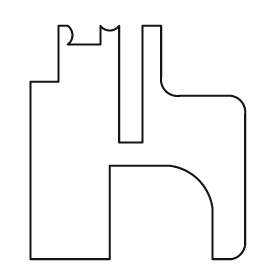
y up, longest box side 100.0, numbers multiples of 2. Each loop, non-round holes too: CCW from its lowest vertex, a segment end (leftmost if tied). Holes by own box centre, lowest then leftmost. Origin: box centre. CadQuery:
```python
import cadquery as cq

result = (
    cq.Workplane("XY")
    .moveTo(-46.0, -50.0)
    .lineTo(-12.0, -50.0)
    .lineTo(-12.0, -10.0)
    .lineTo(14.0, -10.0)
    .threePointArc((26.0, -16.0), (32.0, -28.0))
    .lineTo(32.0, -50.0)
    .lineTo(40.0, -50.0)
    .threePointArc((44.0, -48.0), (46.0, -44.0))
    .lineTo(46.0, 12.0)
    .threePointArc((44.0, 18.0), (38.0, 20.0))
    .lineTo(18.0, 20.0)
    .threePointArc((12.0, 22.0), (10.0, 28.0))
    .lineTo(10.0, 50.0)
    .lineTo(2.0, 50.0)
    .lineTo(2.0, 0.0)
    .lineTo(-8.0, 0.0)
    .lineTo(-8.0, 50.0)
    .threePointArc((-12.0, 48.0), (-16.0, 50.0))
    .lineTo(-16.0, 42.0)
    .lineTo(-30.0, 42.0)
    .threePointArc((-28.0, 46.0), (-30.0, 50.0))
    .lineTo(-34.0, 50.0)
    .lineTo(-34.0, 26.0)
    .lineTo(-46.0, 26.0)
    .close()
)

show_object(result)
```